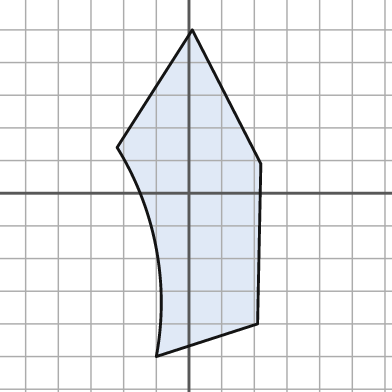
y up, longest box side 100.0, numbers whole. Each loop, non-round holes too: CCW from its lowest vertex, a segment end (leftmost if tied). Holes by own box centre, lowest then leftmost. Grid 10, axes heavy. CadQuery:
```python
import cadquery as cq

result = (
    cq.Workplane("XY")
    .moveTo(-10.0, -50.0)
    .lineTo(21.0, -40.0)
    .lineTo(22.0, 9.0)
    .lineTo(1.0, 50.0)
    .lineTo(-22.0, 14.0)
    .threePointArc((-10.0, -17.0), (-10.0, -50.0))
    .close()
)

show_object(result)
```